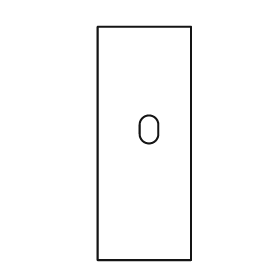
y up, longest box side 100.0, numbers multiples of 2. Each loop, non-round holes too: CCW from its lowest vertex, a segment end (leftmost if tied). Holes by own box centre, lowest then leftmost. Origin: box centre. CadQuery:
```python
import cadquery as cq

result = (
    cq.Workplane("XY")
    .moveTo(-20.0, -50.0)
    .lineTo(20.0, -50.0)
    .lineTo(20.0, 50.0)
    .lineTo(-20.0, 50.0)
    .close()
    .moveTo(-2.0, 4.0)
    .threePointArc((2.0, 0.0), (6.0, 4.0))
    .lineTo(6.0, 8.0)
    .threePointArc((2.0, 12.0), (-2.0, 8.0))
    .close()
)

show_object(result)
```